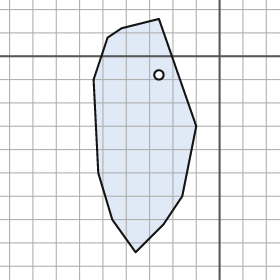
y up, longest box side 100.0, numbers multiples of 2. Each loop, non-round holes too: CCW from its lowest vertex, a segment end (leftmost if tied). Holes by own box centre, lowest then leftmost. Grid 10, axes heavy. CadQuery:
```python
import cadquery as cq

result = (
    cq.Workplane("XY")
    .moveTo(-36.0, -84.0)
    .lineTo(-24.0, -72.0)
    .lineTo(-16.0, -60.0)
    .lineTo(-10.0, -30.0)
    .lineTo(-26.0, 16.0)
    .lineTo(-42.0, 12.0)
    .lineTo(-48.0, 8.0)
    .lineTo(-54.0, -10.0)
    .lineTo(-52.0, -50.0)
    .lineTo(-46.0, -70.0)
    .close()
    .moveTo(-26.0, -8.0)
    .circle(2.0)
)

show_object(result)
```